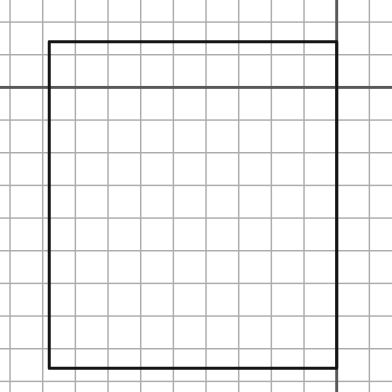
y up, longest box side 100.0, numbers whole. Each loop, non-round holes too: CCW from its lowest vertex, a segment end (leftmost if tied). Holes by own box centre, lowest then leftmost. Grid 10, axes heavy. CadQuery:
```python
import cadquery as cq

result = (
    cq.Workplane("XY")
    .moveTo(-88.0, -86.0)
    .lineTo(0.0, -86.0)
    .lineTo(0.0, 14.0)
    .lineTo(-88.0, 14.0)
    .close()
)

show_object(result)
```